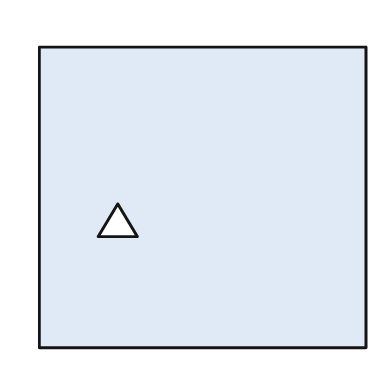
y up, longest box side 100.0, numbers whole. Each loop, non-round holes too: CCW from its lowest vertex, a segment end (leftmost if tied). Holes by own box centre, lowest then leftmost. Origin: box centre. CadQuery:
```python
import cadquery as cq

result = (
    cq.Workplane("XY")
    .moveTo(-50.0, -46.0)
    .lineTo(50.0, -46.0)
    .lineTo(50.0, 46.0)
    .lineTo(-50.0, 46.0)
    .close()
    .moveTo(-32.0, -12.0)
    .lineTo(-20.0, -12.0)
    .lineTo(-26.0, -2.0)
    .close()
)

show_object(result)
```